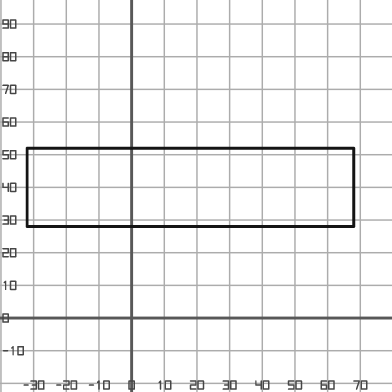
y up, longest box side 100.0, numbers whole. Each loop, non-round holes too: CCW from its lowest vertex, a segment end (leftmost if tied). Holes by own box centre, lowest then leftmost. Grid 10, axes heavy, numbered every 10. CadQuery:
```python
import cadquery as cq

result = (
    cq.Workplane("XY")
    .moveTo(-32.0, 28.0)
    .lineTo(68.0, 28.0)
    .lineTo(68.0, 52.0)
    .lineTo(-32.0, 52.0)
    .close()
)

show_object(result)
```